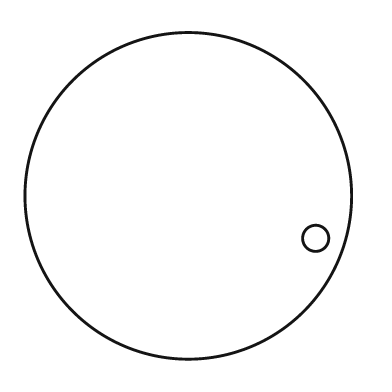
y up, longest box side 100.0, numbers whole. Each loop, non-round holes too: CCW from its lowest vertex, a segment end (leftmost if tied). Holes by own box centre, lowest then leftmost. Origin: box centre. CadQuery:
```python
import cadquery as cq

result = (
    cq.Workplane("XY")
    .moveTo(0.0, 0.0)
    .circle(50.0)
    .moveTo(39.0, -13.0)
    .circle(4.0)
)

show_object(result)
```